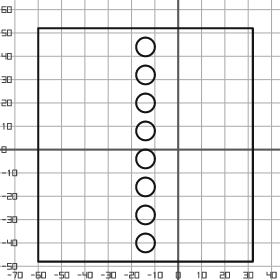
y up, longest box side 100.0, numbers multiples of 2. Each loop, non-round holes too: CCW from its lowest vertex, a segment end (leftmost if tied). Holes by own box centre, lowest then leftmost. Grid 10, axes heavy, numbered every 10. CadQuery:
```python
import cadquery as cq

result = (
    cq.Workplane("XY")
    .moveTo(-60.0, -48.0)
    .lineTo(32.0, -48.0)
    .lineTo(32.0, 52.0)
    .lineTo(-60.0, 52.0)
    .close()
    .moveTo(-14.0, -40.0)
    .circle(4.0)
    .moveTo(-14.0, -28.0)
    .circle(4.0)
    .moveTo(-14.0, -16.0)
    .circle(4.0)
    .moveTo(-14.0, -4.0)
    .circle(4.0)
    .moveTo(-14.0, 8.0)
    .circle(4.0)
    .moveTo(-14.0, 20.0)
    .circle(4.0)
    .moveTo(-14.0, 32.0)
    .circle(4.0)
    .moveTo(-14.0, 44.0)
    .circle(4.0)
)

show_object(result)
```